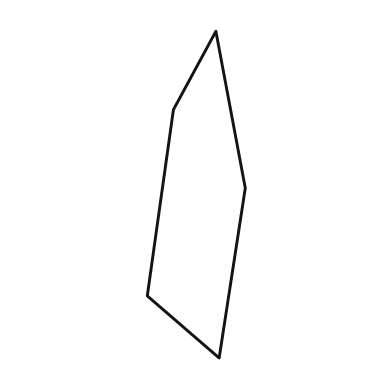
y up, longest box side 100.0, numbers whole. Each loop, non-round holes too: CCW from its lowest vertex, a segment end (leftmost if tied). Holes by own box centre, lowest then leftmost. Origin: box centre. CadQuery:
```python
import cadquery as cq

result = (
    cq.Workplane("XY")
    .moveTo(7.0, -50.0)
    .lineTo(15.0, 2.0)
    .lineTo(6.0, 50.0)
    .lineTo(-7.0, 26.0)
    .lineTo(-15.0, -31.0)
    .close()
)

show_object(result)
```